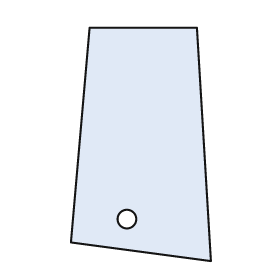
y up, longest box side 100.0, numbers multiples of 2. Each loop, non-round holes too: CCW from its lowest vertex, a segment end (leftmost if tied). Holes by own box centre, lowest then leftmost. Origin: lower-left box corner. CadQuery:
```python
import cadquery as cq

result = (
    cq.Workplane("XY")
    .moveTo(60.0, 0.0)
    .lineTo(54.0, 100.0)
    .lineTo(8.0, 100.0)
    .lineTo(0.0, 8.0)
    .close()
    .moveTo(24.0, 18.0)
    .circle(4.0)
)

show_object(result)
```